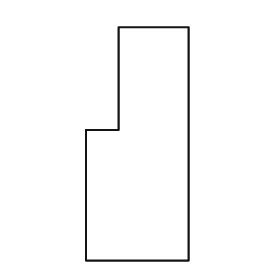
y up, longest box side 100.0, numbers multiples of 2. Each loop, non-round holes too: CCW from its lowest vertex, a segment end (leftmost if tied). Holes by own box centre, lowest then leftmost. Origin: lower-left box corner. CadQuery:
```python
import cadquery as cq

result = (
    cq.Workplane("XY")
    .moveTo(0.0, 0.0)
    .lineTo(44.0, 0.0)
    .lineTo(44.0, 100.0)
    .lineTo(14.0, 100.0)
    .lineTo(14.0, 56.0)
    .lineTo(0.0, 56.0)
    .close()
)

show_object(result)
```